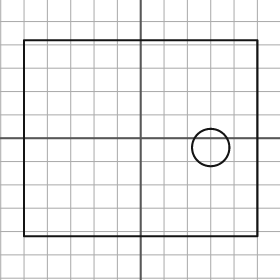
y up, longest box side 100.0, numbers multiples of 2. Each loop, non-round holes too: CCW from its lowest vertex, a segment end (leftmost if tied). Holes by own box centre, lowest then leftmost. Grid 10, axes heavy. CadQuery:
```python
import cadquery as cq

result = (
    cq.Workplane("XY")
    .moveTo(-50.0, -42.0)
    .lineTo(50.0, -42.0)
    .lineTo(50.0, 42.0)
    .lineTo(-50.0, 42.0)
    .close()
    .moveTo(30.0, -4.0)
    .circle(8.0)
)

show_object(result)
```